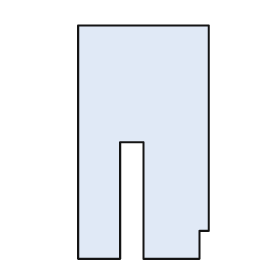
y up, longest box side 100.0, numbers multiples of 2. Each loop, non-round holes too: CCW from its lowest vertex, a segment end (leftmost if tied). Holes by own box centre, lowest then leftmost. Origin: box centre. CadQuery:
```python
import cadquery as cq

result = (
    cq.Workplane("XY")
    .moveTo(-28.0, -50.0)
    .lineTo(-10.0, -50.0)
    .lineTo(-10.0, 0.0)
    .lineTo(0.0, 0.0)
    .lineTo(0.0, -50.0)
    .lineTo(24.0, -50.0)
    .lineTo(24.0, -38.0)
    .lineTo(28.0, -38.0)
    .lineTo(28.0, 50.0)
    .lineTo(-28.0, 50.0)
    .close()
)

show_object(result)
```